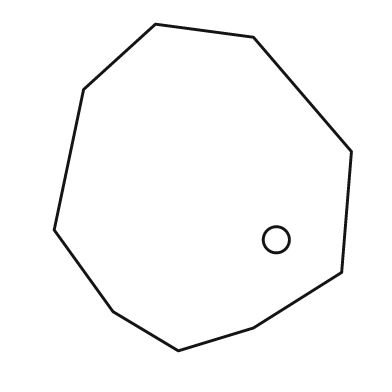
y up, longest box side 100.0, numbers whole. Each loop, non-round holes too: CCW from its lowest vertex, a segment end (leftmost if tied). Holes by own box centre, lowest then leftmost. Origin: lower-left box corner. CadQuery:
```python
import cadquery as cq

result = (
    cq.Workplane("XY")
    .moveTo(38.0, 0.0)
    .lineTo(61.0, 7.0)
    .lineTo(88.0, 24.0)
    .lineTo(91.0, 61.0)
    .lineTo(61.0, 96.0)
    .lineTo(31.0, 100.0)
    .lineTo(9.0, 80.0)
    .lineTo(0.0, 37.0)
    .lineTo(18.0, 12.0)
    .close()
    .moveTo(68.0, 34.0)
    .circle(4.0)
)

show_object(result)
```